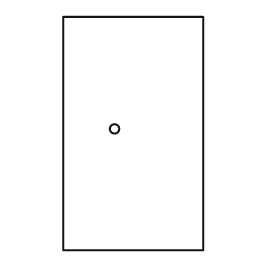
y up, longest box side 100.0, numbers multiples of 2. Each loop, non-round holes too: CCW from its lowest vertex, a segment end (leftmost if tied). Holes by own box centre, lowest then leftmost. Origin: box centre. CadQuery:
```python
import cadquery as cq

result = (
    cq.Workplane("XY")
    .moveTo(-30.0, -50.0)
    .lineTo(30.0, -50.0)
    .lineTo(30.0, 50.0)
    .lineTo(-30.0, 50.0)
    .close()
    .moveTo(-8.0, 2.0)
    .circle(2.0)
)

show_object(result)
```